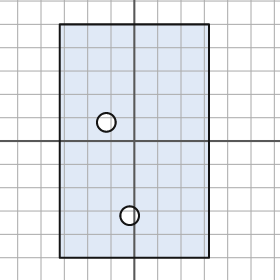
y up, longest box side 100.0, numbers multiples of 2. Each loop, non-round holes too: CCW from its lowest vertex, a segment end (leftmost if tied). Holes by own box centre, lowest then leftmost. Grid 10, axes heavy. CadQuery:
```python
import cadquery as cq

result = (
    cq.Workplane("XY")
    .moveTo(-32.0, -50.0)
    .lineTo(32.0, -50.0)
    .lineTo(32.0, 50.0)
    .lineTo(-32.0, 50.0)
    .close()
    .moveTo(-2.0, -32.0)
    .circle(4.0)
    .moveTo(-12.0, 8.0)
    .circle(4.0)
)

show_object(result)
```